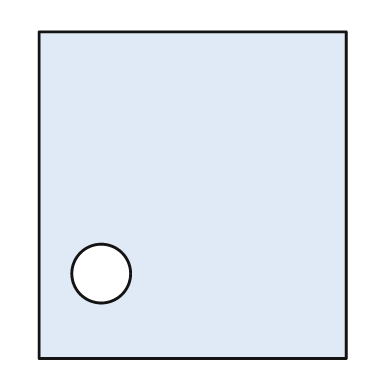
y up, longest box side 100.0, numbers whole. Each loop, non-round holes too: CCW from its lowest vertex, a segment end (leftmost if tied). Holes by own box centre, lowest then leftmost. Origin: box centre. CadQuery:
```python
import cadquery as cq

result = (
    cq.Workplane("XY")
    .moveTo(-47.0, -50.0)
    .lineTo(47.0, -50.0)
    .lineTo(47.0, 50.0)
    .lineTo(-47.0, 50.0)
    .close()
    .moveTo(-28.0, -24.0)
    .circle(9.0)
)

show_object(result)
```